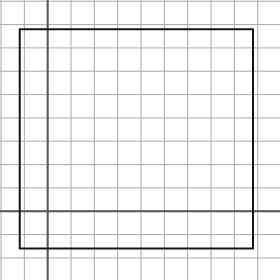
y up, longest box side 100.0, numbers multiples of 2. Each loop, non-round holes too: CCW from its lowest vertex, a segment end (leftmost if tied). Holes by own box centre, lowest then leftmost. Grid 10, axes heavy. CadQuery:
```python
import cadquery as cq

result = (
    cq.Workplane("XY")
    .moveTo(-12.0, -16.0)
    .lineTo(88.0, -16.0)
    .lineTo(88.0, 78.0)
    .lineTo(-12.0, 78.0)
    .close()
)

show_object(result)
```